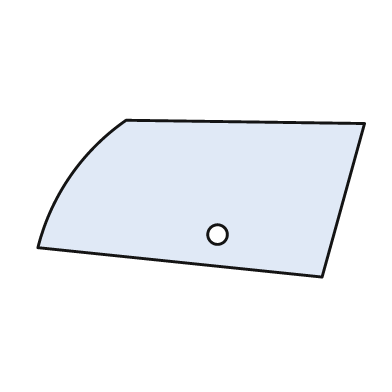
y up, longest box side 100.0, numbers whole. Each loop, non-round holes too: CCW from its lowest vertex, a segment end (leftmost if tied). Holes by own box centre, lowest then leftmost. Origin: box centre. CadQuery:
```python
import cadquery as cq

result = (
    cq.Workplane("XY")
    .moveTo(37.0, -24.0)
    .lineTo(50.0, 23.0)
    .lineTo(-23.0, 24.0)
    .threePointArc((-40.0, 7.0), (-50.0, -15.0))
    .close()
    .moveTo(5.0, -11.0)
    .circle(3.0)
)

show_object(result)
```